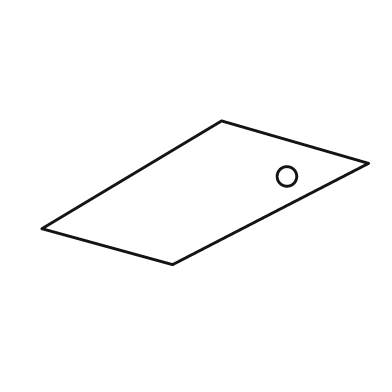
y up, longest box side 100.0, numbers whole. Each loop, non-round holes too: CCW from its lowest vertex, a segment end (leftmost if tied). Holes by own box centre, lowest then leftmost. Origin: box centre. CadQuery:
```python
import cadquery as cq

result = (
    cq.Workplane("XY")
    .moveTo(-10.0, -22.0)
    .lineTo(50.0, 9.0)
    .lineTo(5.0, 22.0)
    .lineTo(-50.0, -11.0)
    .close()
    .moveTo(25.0, 5.0)
    .circle(3.0)
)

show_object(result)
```